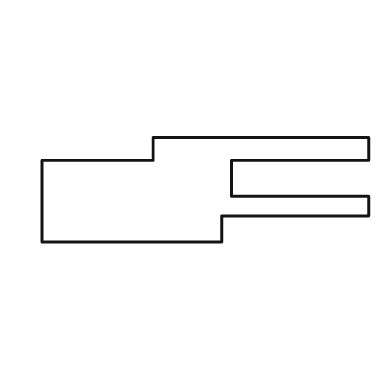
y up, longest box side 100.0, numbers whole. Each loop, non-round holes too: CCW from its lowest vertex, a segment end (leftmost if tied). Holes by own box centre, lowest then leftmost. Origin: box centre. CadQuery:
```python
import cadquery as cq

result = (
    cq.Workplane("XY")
    .moveTo(-50.0, -16.0)
    .lineTo(5.0, -16.0)
    .lineTo(5.0, -8.0)
    .lineTo(50.0, -8.0)
    .lineTo(50.0, -2.0)
    .lineTo(8.0, -2.0)
    .lineTo(8.0, 9.0)
    .lineTo(50.0, 9.0)
    .lineTo(50.0, 16.0)
    .lineTo(-16.0, 16.0)
    .lineTo(-16.0, 9.0)
    .lineTo(-50.0, 9.0)
    .close()
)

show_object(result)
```